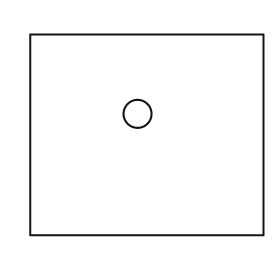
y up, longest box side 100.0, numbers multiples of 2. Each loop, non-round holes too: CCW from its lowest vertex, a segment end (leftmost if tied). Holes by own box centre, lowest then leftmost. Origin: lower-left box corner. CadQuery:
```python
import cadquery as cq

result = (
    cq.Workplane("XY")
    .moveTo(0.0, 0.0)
    .lineTo(100.0, 0.0)
    .lineTo(100.0, 86.0)
    .lineTo(0.0, 86.0)
    .close()
    .moveTo(46.0, 52.0)
    .circle(6.0)
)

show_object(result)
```